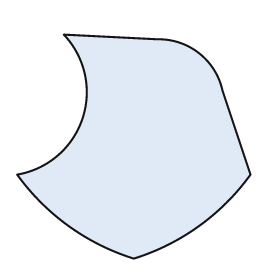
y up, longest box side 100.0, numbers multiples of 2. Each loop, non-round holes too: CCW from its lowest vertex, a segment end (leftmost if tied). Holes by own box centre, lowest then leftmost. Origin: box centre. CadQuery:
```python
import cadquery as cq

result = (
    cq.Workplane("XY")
    .moveTo(0.0, -48.0)
    .threePointArc((28.0, -34.0), (50.0, -12.0))
    .lineTo(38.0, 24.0)
    .threePointArc((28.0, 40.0), (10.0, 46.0))
    .lineTo(-30.0, 48.0)
    .threePointArc((-22.0, 12.0), (-50.0, -12.0))
    .threePointArc((-28.0, -34.0), (0.0, -48.0))
    .close()
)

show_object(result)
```